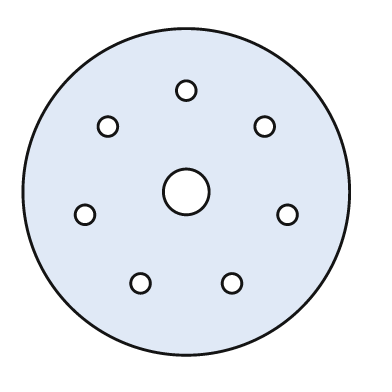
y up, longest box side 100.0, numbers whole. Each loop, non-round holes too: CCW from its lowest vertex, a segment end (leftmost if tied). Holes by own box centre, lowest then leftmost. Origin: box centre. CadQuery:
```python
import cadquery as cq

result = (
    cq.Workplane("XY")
    .moveTo(0.0, 0.0)
    .circle(50.0)
    .moveTo(-14.0, -28.0)
    .circle(3.0)
    .moveTo(14.0, -28.0)
    .circle(3.0)
    .moveTo(-31.0, -7.0)
    .circle(3.0)
    .moveTo(31.0, -7.0)
    .circle(3.0)
    .moveTo(0.0, 0.0)
    .circle(7.0)
    .moveTo(-24.0, 20.0)
    .circle(3.0)
    .moveTo(24.0, 20.0)
    .circle(3.0)
    .moveTo(0.0, 31.0)
    .circle(3.0)
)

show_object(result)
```